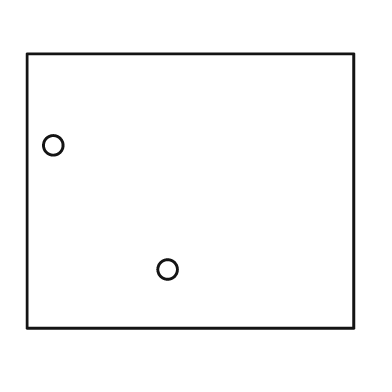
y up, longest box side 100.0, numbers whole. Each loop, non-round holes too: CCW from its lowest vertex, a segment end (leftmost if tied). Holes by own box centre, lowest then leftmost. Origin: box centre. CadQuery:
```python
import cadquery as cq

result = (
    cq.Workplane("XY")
    .moveTo(-50.0, -42.0)
    .lineTo(50.0, -42.0)
    .lineTo(50.0, 42.0)
    .lineTo(-50.0, 42.0)
    .close()
    .moveTo(-7.0, -24.0)
    .circle(3.0)
    .moveTo(-42.0, 14.0)
    .circle(3.0)
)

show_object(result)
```